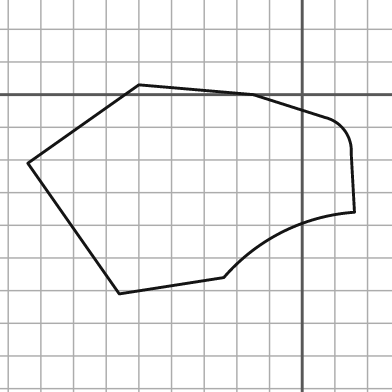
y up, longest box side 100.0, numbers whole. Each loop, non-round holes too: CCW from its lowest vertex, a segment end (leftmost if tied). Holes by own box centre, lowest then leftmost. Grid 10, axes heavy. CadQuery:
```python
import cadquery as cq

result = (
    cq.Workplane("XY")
    .moveTo(-56.0, -61.0)
    .lineTo(-24.0, -56.0)
    .threePointArc((-6.0, -42.0), (16.0, -36.0))
    .lineTo(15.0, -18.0)
    .threePointArc((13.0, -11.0), (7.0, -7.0))
    .lineTo(-15.0, 0.0)
    .lineTo(-50.0, 3.0)
    .lineTo(-84.0, -21.0)
    .close()
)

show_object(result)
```